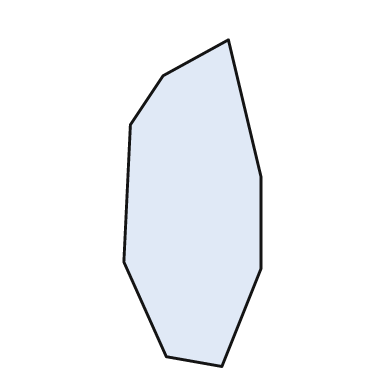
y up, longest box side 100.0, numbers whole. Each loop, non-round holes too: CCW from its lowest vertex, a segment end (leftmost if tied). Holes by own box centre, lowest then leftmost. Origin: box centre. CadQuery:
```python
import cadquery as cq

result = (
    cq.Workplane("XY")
    .moveTo(9.0, -50.0)
    .lineTo(21.0, -20.0)
    .lineTo(21.0, 8.0)
    .lineTo(11.0, 50.0)
    .lineTo(-9.0, 39.0)
    .lineTo(-19.0, 24.0)
    .lineTo(-21.0, -18.0)
    .lineTo(-8.0, -47.0)
    .close()
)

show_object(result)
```